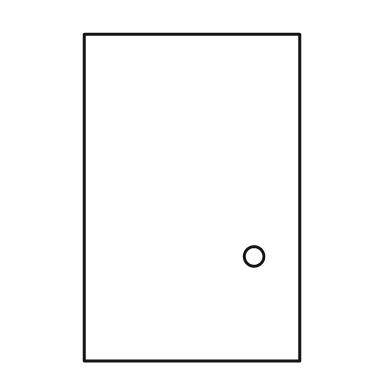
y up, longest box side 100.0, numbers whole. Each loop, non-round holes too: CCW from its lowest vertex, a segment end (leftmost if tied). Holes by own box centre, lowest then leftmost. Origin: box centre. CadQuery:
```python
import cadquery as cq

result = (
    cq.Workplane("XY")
    .moveTo(-33.0, -50.0)
    .lineTo(33.0, -50.0)
    .lineTo(33.0, 50.0)
    .lineTo(-33.0, 50.0)
    .close()
    .moveTo(19.0, -18.0)
    .circle(3.0)
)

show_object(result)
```